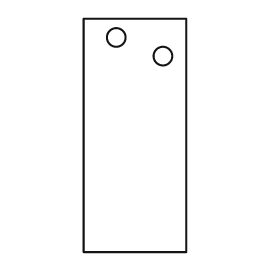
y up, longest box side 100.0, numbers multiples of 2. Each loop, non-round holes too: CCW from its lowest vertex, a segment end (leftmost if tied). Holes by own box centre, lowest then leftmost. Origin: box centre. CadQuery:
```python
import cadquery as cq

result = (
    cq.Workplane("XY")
    .moveTo(-22.0, -50.0)
    .lineTo(22.0, -50.0)
    .lineTo(22.0, 50.0)
    .lineTo(-22.0, 50.0)
    .close()
    .moveTo(12.0, 34.0)
    .circle(4.0)
    .moveTo(-8.0, 42.0)
    .circle(4.0)
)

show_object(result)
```